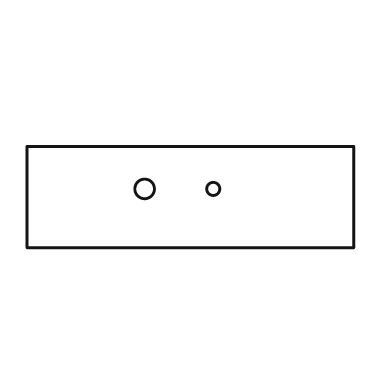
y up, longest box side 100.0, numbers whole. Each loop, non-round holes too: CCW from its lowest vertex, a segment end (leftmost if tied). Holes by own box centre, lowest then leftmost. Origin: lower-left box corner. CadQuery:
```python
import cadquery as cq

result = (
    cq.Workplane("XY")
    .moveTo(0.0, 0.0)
    .lineTo(100.0, 0.0)
    .lineTo(100.0, 31.0)
    .lineTo(0.0, 31.0)
    .close()
    .moveTo(36.0, 18.0)
    .circle(3.0)
    .moveTo(57.0, 18.0)
    .circle(2.0)
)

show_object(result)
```